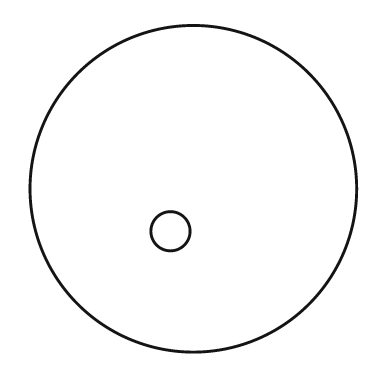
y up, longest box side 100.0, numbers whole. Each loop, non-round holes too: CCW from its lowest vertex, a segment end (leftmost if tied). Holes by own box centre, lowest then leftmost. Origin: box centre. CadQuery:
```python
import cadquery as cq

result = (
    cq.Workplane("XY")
    .moveTo(0.0, 0.0)
    .circle(50.0)
    .moveTo(-7.0, -13.0)
    .circle(6.0)
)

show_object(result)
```